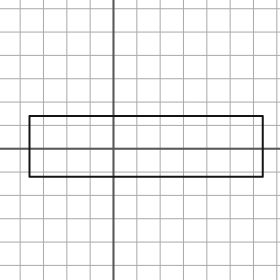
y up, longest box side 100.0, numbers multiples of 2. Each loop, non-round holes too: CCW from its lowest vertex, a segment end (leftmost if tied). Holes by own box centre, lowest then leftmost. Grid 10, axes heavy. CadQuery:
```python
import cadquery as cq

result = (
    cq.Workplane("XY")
    .moveTo(-36.0, -12.0)
    .lineTo(64.0, -12.0)
    .lineTo(64.0, 14.0)
    .lineTo(-36.0, 14.0)
    .close()
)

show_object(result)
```